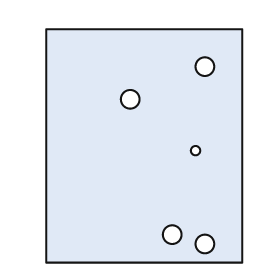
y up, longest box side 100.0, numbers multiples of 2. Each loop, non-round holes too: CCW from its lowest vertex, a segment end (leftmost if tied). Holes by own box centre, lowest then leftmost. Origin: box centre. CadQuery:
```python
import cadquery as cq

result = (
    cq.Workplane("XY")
    .moveTo(-42.0, -50.0)
    .lineTo(42.0, -50.0)
    .lineTo(42.0, 50.0)
    .lineTo(-42.0, 50.0)
    .close()
    .moveTo(26.0, -42.0)
    .circle(4.0)
    .moveTo(12.0, -38.0)
    .circle(4.0)
    .moveTo(22.0, -2.0)
    .circle(2.0)
    .moveTo(-6.0, 20.0)
    .circle(4.0)
    .moveTo(26.0, 34.0)
    .circle(4.0)
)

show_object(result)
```